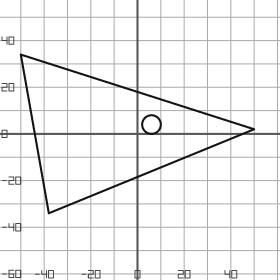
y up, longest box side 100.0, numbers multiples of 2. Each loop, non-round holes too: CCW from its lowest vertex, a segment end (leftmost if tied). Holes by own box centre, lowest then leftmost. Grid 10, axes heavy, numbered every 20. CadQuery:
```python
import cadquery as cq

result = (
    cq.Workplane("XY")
    .moveTo(-38.0, -34.0)
    .lineTo(50.0, 2.0)
    .lineTo(-50.0, 34.0)
    .close()
    .moveTo(6.0, 4.0)
    .circle(4.0)
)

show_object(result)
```